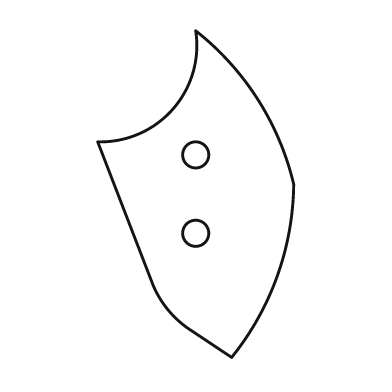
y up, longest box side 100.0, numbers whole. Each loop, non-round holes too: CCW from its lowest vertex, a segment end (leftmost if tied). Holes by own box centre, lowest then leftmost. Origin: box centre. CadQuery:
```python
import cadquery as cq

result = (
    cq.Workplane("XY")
    .moveTo(11.0, -50.0)
    .threePointArc((25.0, -25.0), (30.0, 3.0))
    .threePointArc((19.0, 29.0), (0.0, 50.0))
    .threePointArc((-7.0, 26.0), (-30.0, 16.0))
    .lineTo(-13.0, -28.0)
    .threePointArc((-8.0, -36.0), (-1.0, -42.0))
    .close()
    .moveTo(0.0, -12.0)
    .circle(4.0)
    .moveTo(0.0, 12.0)
    .circle(4.0)
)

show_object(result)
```